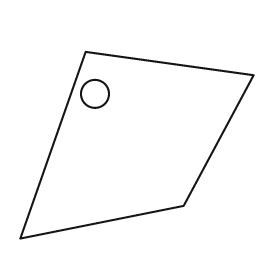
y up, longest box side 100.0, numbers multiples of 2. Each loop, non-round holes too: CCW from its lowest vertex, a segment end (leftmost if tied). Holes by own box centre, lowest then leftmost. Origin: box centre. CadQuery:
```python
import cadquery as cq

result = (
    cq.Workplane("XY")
    .moveTo(-50.0, -40.0)
    .lineTo(20.0, -26.0)
    .lineTo(50.0, 30.0)
    .lineTo(-22.0, 40.0)
    .close()
    .moveTo(-18.0, 22.0)
    .circle(6.0)
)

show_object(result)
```